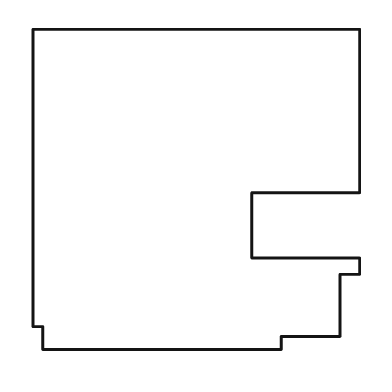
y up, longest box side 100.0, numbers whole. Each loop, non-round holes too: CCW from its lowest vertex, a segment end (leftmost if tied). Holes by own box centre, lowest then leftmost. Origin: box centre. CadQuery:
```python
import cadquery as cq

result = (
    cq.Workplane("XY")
    .moveTo(-47.0, -49.0)
    .lineTo(26.0, -49.0)
    .lineTo(26.0, -45.0)
    .lineTo(44.0, -45.0)
    .lineTo(44.0, -26.0)
    .lineTo(50.0, -26.0)
    .lineTo(50.0, -21.0)
    .lineTo(17.0, -21.0)
    .lineTo(17.0, -1.0)
    .lineTo(50.0, -1.0)
    .lineTo(50.0, 49.0)
    .lineTo(-50.0, 49.0)
    .lineTo(-50.0, -42.0)
    .lineTo(-47.0, -42.0)
    .close()
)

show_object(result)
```